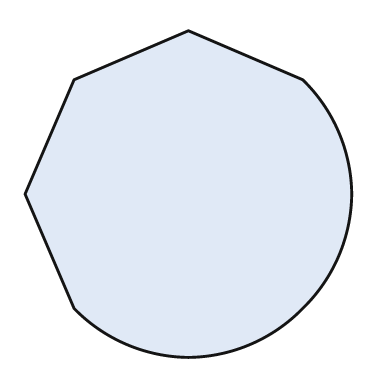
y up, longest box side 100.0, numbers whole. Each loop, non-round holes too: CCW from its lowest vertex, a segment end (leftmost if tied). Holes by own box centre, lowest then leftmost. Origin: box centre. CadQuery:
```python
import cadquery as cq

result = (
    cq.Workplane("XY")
    .moveTo(0.0, -50.0)
    .threePointArc((19.0, -46.0), (35.0, -35.0))
    .threePointArc((46.0, -19.0), (50.0, 0.0))
    .threePointArc((46.0, 19.0), (35.0, 35.0))
    .lineTo(0.0, 50.0)
    .lineTo(-35.0, 35.0)
    .lineTo(-50.0, 0.0)
    .lineTo(-35.0, -35.0)
    .threePointArc((-19.0, -46.0), (0.0, -50.0))
    .close()
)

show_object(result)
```